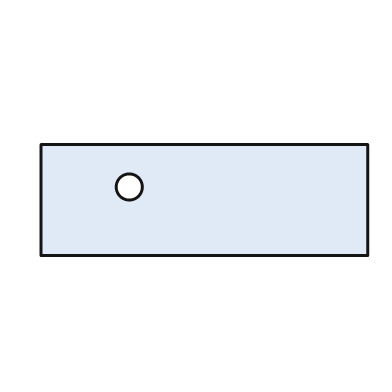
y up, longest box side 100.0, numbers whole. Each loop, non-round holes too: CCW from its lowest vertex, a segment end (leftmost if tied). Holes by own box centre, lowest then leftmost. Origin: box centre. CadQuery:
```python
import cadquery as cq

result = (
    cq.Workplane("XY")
    .moveTo(-50.0, -17.0)
    .lineTo(50.0, -17.0)
    .lineTo(50.0, 17.0)
    .lineTo(-50.0, 17.0)
    .close()
    .moveTo(-23.0, 4.0)
    .circle(4.0)
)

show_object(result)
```